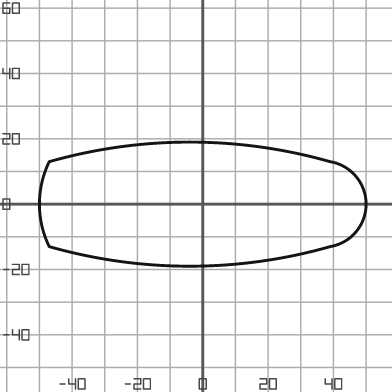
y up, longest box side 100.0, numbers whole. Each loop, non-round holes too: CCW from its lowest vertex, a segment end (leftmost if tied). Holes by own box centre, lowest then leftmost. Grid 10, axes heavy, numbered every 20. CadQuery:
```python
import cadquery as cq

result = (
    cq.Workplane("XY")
    .moveTo(-47.0, -13.0)
    .threePointArc((-4.0, -19.0), (39.0, -13.0))
    .threePointArc((50.0, 0.0), (39.0, 13.0))
    .threePointArc((-4.0, 19.0), (-47.0, 13.0))
    .threePointArc((-50.0, 0.0), (-47.0, -13.0))
    .close()
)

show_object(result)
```